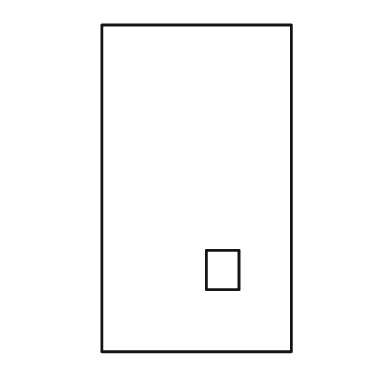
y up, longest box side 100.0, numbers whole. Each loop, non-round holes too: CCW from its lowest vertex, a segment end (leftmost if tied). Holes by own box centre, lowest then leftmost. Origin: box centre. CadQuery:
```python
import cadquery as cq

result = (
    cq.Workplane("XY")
    .moveTo(-29.0, -50.0)
    .lineTo(29.0, -50.0)
    .lineTo(29.0, 50.0)
    .lineTo(-29.0, 50.0)
    .close()
    .moveTo(3.0, -31.0)
    .lineTo(13.0, -31.0)
    .lineTo(13.0, -19.0)
    .lineTo(3.0, -19.0)
    .close()
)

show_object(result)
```